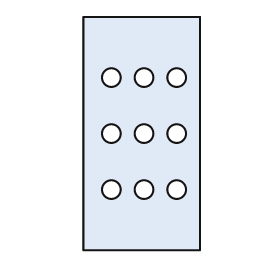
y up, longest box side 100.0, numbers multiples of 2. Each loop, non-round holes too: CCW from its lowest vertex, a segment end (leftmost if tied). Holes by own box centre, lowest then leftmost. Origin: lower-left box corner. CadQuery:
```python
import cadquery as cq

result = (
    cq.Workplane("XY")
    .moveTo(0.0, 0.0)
    .lineTo(50.0, 0.0)
    .lineTo(50.0, 100.0)
    .lineTo(0.0, 100.0)
    .close()
    .moveTo(12.0, 26.0)
    .circle(4.0)
    .moveTo(26.0, 26.0)
    .circle(4.0)
    .moveTo(40.0, 26.0)
    .circle(4.0)
    .moveTo(12.0, 50.0)
    .circle(4.0)
    .moveTo(26.0, 50.0)
    .circle(4.0)
    .moveTo(40.0, 50.0)
    .circle(4.0)
    .moveTo(12.0, 74.0)
    .circle(4.0)
    .moveTo(26.0, 74.0)
    .circle(4.0)
    .moveTo(40.0, 74.0)
    .circle(4.0)
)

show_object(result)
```